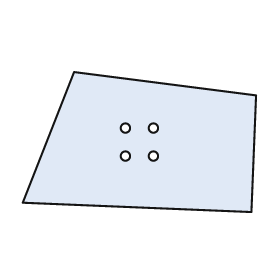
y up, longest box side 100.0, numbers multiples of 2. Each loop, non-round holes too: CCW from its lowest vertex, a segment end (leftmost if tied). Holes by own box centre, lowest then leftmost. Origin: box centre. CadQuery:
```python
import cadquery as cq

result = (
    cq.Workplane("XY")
    .moveTo(48.0, -30.0)
    .lineTo(50.0, 20.0)
    .lineTo(-28.0, 30.0)
    .lineTo(-50.0, -26.0)
    .close()
    .moveTo(-6.0, -6.0)
    .circle(2.0)
    .moveTo(6.0, -6.0)
    .circle(2.0)
    .moveTo(-6.0, 6.0)
    .circle(2.0)
    .moveTo(6.0, 6.0)
    .circle(2.0)
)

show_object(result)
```